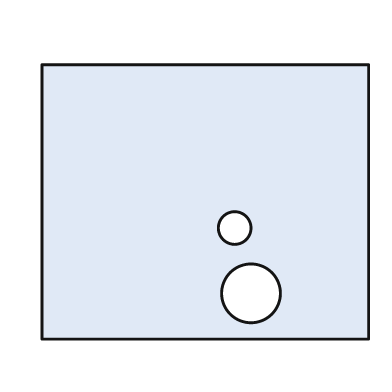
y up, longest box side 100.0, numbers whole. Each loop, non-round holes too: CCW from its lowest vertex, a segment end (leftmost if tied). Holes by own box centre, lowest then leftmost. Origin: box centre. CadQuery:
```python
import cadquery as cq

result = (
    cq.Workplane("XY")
    .moveTo(-50.0, -42.0)
    .lineTo(50.0, -42.0)
    .lineTo(50.0, 42.0)
    .lineTo(-50.0, 42.0)
    .close()
    .moveTo(14.0, -28.0)
    .circle(9.0)
    .moveTo(9.0, -8.0)
    .circle(5.0)
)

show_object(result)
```